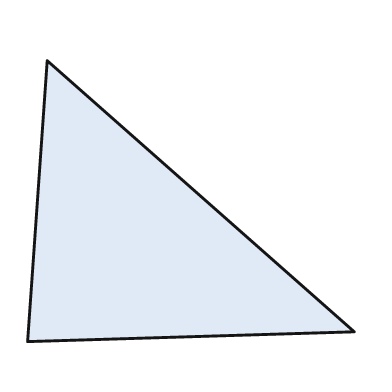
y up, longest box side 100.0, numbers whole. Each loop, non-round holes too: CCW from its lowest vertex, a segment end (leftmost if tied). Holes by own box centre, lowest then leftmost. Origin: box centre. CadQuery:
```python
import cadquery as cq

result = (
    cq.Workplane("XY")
    .moveTo(-50.0, -43.0)
    .lineTo(50.0, -40.0)
    .lineTo(-44.0, 43.0)
    .close()
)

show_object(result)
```